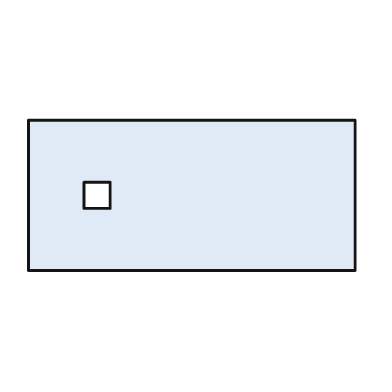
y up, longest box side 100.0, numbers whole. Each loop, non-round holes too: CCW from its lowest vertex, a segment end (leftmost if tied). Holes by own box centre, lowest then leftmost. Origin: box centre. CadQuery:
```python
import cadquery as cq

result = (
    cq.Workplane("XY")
    .moveTo(-50.0, -23.0)
    .lineTo(50.0, -23.0)
    .lineTo(50.0, 23.0)
    .lineTo(-50.0, 23.0)
    .close()
    .moveTo(-33.0, -4.0)
    .lineTo(-25.0, -4.0)
    .lineTo(-25.0, 4.0)
    .lineTo(-33.0, 4.0)
    .close()
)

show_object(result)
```